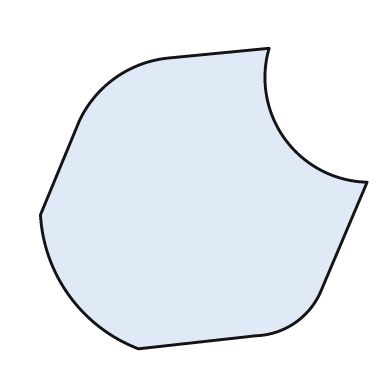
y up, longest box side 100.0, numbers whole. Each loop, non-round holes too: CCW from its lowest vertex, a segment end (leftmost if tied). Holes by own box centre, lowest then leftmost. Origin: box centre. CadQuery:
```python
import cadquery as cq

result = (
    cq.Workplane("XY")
    .moveTo(-20.0, -46.0)
    .lineTo(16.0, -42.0)
    .threePointArc((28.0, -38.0), (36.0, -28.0))
    .lineTo(50.0, 5.0)
    .threePointArc((25.0, 18.0), (20.0, 46.0))
    .lineTo(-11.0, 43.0)
    .threePointArc((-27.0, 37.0), (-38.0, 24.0))
    .lineTo(-50.0, -5.0)
    .threePointArc((-41.0, -30.0), (-20.0, -46.0))
    .close()
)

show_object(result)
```